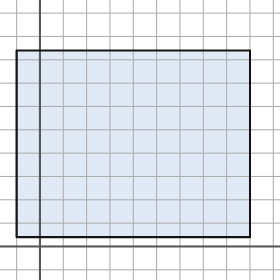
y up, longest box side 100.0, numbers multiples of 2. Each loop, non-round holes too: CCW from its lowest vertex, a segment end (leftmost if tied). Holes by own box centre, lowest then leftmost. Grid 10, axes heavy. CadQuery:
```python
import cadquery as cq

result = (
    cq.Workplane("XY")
    .moveTo(-10.0, 4.0)
    .lineTo(90.0, 4.0)
    .lineTo(90.0, 84.0)
    .lineTo(-10.0, 84.0)
    .close()
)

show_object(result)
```